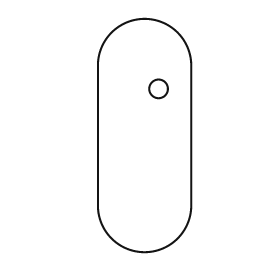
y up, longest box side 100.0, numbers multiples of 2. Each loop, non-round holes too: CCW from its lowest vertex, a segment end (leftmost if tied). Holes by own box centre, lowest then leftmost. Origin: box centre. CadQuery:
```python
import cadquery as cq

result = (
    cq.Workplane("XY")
    .moveTo(-20.0, -30.0)
    .threePointArc((0.0, -50.0), (20.0, -30.0))
    .lineTo(20.0, 30.0)
    .threePointArc((0.0, 50.0), (-20.0, 30.0))
    .close()
    .moveTo(6.0, 20.0)
    .circle(4.0)
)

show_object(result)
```